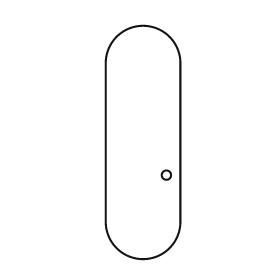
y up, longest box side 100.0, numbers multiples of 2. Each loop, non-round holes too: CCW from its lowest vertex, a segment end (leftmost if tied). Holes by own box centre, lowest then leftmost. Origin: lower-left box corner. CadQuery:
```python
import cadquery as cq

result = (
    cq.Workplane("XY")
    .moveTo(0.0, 16.0)
    .threePointArc((16.0, 0.0), (32.0, 16.0))
    .lineTo(32.0, 84.0)
    .threePointArc((16.0, 100.0), (0.0, 84.0))
    .close()
    .moveTo(26.0, 36.0)
    .circle(2.0)
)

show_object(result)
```